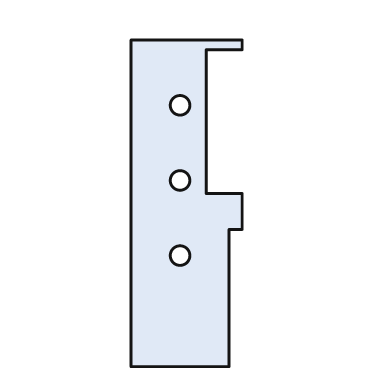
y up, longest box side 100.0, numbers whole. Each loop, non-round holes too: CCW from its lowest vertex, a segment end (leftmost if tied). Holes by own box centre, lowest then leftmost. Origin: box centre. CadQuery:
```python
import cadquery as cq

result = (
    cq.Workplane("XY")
    .moveTo(-17.0, -50.0)
    .lineTo(13.0, -50.0)
    .lineTo(13.0, -8.0)
    .lineTo(17.0, -8.0)
    .lineTo(17.0, 3.0)
    .lineTo(6.0, 3.0)
    .lineTo(6.0, 47.0)
    .lineTo(17.0, 47.0)
    .lineTo(17.0, 50.0)
    .lineTo(-17.0, 50.0)
    .close()
    .moveTo(-2.0, -16.0)
    .circle(3.0)
    .moveTo(-2.0, 7.0)
    .circle(3.0)
    .moveTo(-2.0, 30.0)
    .circle(3.0)
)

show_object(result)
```